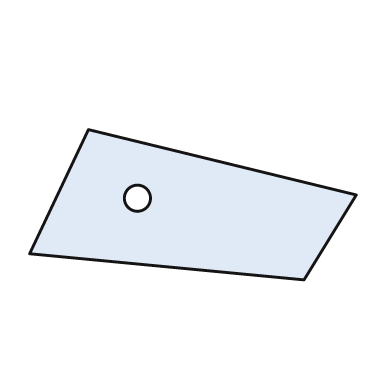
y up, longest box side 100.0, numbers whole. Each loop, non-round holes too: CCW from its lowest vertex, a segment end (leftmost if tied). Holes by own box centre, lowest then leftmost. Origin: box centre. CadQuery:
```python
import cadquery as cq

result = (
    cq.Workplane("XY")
    .moveTo(34.0, -23.0)
    .lineTo(50.0, 3.0)
    .lineTo(-32.0, 23.0)
    .lineTo(-50.0, -15.0)
    .close()
    .moveTo(-17.0, 2.0)
    .circle(4.0)
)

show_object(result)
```